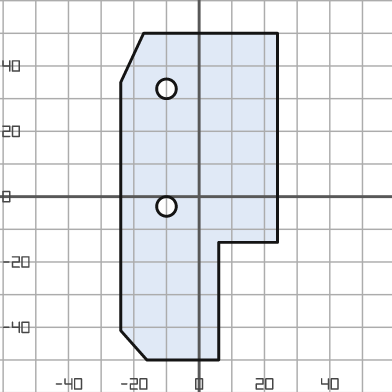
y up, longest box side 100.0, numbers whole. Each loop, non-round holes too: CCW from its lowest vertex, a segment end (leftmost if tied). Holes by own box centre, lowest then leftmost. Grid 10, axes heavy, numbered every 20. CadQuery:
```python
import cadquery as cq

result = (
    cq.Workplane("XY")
    .moveTo(-16.0, -50.0)
    .lineTo(6.0, -50.0)
    .lineTo(6.0, -14.0)
    .lineTo(24.0, -14.0)
    .lineTo(24.0, 50.0)
    .lineTo(-17.0, 50.0)
    .lineTo(-24.0, 35.0)
    .lineTo(-24.0, -41.0)
    .close()
    .moveTo(-10.0, -3.0)
    .circle(3.0)
    .moveTo(-10.0, 33.0)
    .circle(3.0)
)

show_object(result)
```